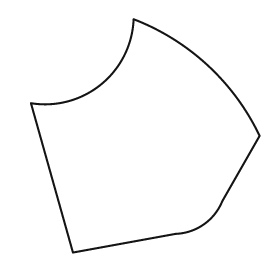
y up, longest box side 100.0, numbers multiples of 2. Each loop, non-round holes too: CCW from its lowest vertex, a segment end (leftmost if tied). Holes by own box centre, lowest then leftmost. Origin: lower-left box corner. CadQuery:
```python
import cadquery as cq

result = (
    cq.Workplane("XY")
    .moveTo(18.0, 0.0)
    .lineTo(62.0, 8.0)
    .threePointArc((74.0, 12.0), (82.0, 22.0))
    .lineTo(98.0, 50.0)
    .threePointArc((76.0, 80.0), (44.0, 100.0))
    .threePointArc((30.0, 72.0), (0.0, 64.0))
    .close()
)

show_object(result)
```